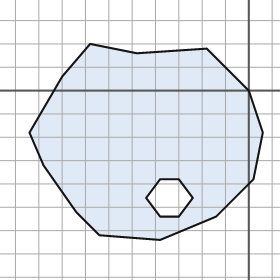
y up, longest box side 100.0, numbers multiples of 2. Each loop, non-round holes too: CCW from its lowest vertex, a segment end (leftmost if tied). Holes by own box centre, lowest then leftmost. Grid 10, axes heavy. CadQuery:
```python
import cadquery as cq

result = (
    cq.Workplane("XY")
    .moveTo(-38.0, -64.0)
    .lineTo(-14.0, -54.0)
    .lineTo(2.0, -38.0)
    .lineTo(6.0, -18.0)
    .lineTo(0.0, 0.0)
    .lineTo(-18.0, 18.0)
    .lineTo(-48.0, 16.0)
    .lineTo(-68.0, 20.0)
    .lineTo(-80.0, 6.0)
    .lineTo(-94.0, -18.0)
    .lineTo(-88.0, -32.0)
    .lineTo(-74.0, -52.0)
    .lineTo(-64.0, -62.0)
    .close()
    .moveTo(-38.0, -54.0)
    .lineTo(-30.0, -54.0)
    .lineTo(-24.0, -46.0)
    .lineTo(-30.0, -38.0)
    .lineTo(-38.0, -38.0)
    .lineTo(-44.0, -46.0)
    .close()
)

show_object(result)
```